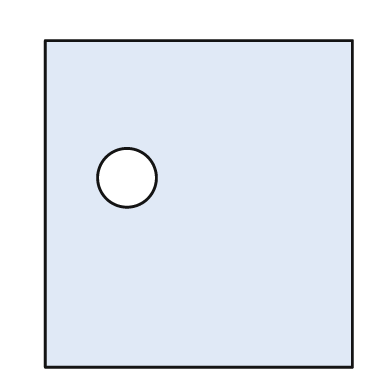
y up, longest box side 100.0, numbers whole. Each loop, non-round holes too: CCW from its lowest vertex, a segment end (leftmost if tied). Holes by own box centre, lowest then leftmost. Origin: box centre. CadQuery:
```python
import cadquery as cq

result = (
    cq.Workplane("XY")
    .moveTo(-47.0, -50.0)
    .lineTo(47.0, -50.0)
    .lineTo(47.0, 50.0)
    .lineTo(-47.0, 50.0)
    .close()
    .moveTo(-22.0, 8.0)
    .circle(9.0)
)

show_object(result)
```